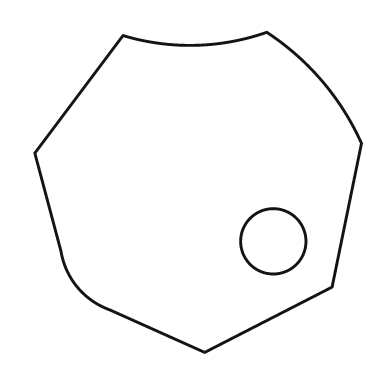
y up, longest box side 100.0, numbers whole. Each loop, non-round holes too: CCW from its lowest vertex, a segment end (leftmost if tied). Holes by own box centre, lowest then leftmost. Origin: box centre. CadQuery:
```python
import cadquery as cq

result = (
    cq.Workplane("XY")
    .moveTo(2.0, -49.0)
    .lineTo(41.0, -29.0)
    .lineTo(50.0, 15.0)
    .threePointArc((38.0, 34.0), (21.0, 49.0))
    .threePointArc((-1.0, 45.0), (-23.0, 48.0))
    .lineTo(-50.0, 12.0)
    .lineTo(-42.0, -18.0)
    .threePointArc((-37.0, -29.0), (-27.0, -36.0))
    .close()
    .moveTo(23.0, -15.0)
    .circle(10.0)
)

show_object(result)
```